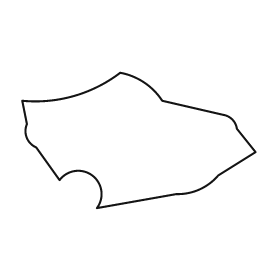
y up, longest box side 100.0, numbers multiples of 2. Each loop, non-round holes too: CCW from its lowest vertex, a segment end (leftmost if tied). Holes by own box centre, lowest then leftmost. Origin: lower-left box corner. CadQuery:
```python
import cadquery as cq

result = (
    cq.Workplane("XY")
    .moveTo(32.0, 0.0)
    .lineTo(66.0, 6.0)
    .threePointArc((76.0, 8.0), (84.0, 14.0))
    .lineTo(100.0, 24.0)
    .lineTo(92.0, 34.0)
    .threePointArc((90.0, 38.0), (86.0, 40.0))
    .lineTo(60.0, 46.0)
    .threePointArc((52.0, 54.0), (42.0, 58.0))
    .threePointArc((22.0, 48.0), (0.0, 46.0))
    .lineTo(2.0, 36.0)
    .threePointArc((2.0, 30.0), (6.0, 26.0))
    .lineTo(16.0, 12.0)
    .threePointArc((30.0, 14.0), (32.0, 0.0))
    .close()
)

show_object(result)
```